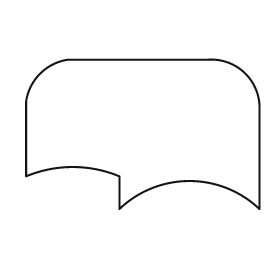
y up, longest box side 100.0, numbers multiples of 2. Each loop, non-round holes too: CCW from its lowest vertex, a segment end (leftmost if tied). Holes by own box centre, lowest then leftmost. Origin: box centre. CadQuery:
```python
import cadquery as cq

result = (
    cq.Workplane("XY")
    .moveTo(-10.0, -32.0)
    .threePointArc((20.0, -20.0), (50.0, -32.0))
    .lineTo(50.0, 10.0)
    .threePointArc((44.0, 26.0), (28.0, 32.0))
    .lineTo(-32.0, 32.0)
    .threePointArc((-44.0, 26.0), (-50.0, 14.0))
    .lineTo(-50.0, -18.0)
    .threePointArc((-30.0, -14.0), (-10.0, -18.0))
    .close()
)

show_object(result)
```